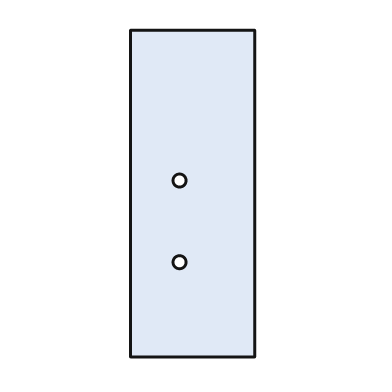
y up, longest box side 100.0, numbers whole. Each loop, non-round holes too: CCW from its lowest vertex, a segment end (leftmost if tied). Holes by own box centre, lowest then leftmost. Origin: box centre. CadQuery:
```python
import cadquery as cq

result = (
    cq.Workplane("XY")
    .moveTo(-19.0, -50.0)
    .lineTo(19.0, -50.0)
    .lineTo(19.0, 50.0)
    .lineTo(-19.0, 50.0)
    .close()
    .moveTo(-4.0, -21.0)
    .circle(2.0)
    .moveTo(-4.0, 4.0)
    .circle(2.0)
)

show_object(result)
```